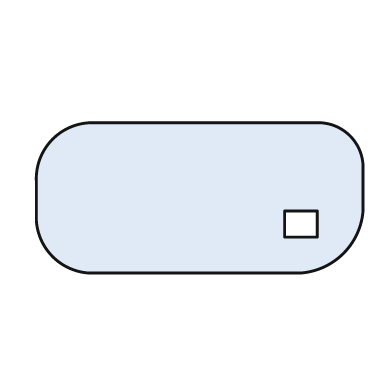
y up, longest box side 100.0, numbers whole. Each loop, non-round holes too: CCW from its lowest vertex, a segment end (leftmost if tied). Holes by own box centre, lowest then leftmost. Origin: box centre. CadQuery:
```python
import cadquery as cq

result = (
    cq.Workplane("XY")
    .moveTo(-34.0, -23.0)
    .lineTo(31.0, -23.0)
    .threePointArc((44.0, -17.0), (50.0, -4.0))
    .lineTo(50.0, 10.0)
    .threePointArc((46.0, 19.0), (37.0, 23.0))
    .lineTo(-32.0, 23.0)
    .threePointArc((-45.0, 18.0), (-50.0, 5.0))
    .lineTo(-50.0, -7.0)
    .threePointArc((-45.0, -18.0), (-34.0, -23.0))
    .close()
    .moveTo(26.0, -12.0)
    .lineTo(36.0, -12.0)
    .lineTo(36.0, -4.0)
    .lineTo(26.0, -4.0)
    .close()
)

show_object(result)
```